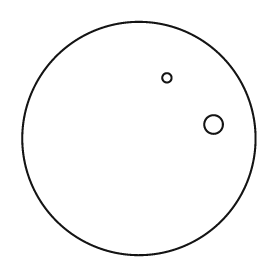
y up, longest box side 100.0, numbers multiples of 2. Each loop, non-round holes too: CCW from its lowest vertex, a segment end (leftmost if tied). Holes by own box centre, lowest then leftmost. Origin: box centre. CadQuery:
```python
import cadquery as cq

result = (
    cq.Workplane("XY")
    .moveTo(0.0, 0.0)
    .circle(50.0)
    .moveTo(32.0, 6.0)
    .circle(4.0)
    .moveTo(12.0, 26.0)
    .circle(2.0)
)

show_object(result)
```